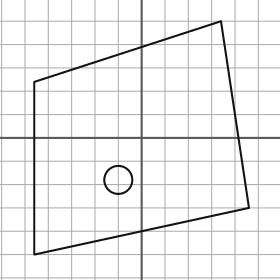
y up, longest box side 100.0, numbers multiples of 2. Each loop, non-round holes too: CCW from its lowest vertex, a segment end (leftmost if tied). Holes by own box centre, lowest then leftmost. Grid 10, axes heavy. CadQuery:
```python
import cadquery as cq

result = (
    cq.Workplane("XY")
    .moveTo(-46.0, -50.0)
    .lineTo(46.0, -30.0)
    .lineTo(34.0, 50.0)
    .lineTo(-46.0, 24.0)
    .close()
    .moveTo(-10.0, -18.0)
    .circle(6.0)
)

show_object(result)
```